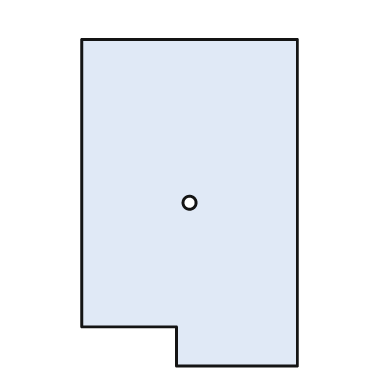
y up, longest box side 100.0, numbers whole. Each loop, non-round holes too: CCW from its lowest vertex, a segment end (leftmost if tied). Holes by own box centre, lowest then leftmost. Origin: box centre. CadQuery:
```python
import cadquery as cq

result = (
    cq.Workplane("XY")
    .moveTo(-4.0, -50.0)
    .lineTo(33.0, -50.0)
    .lineTo(33.0, 50.0)
    .lineTo(-33.0, 50.0)
    .lineTo(-33.0, -38.0)
    .lineTo(-4.0, -38.0)
    .close()
    .moveTo(0.0, 0.0)
    .circle(2.0)
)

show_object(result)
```